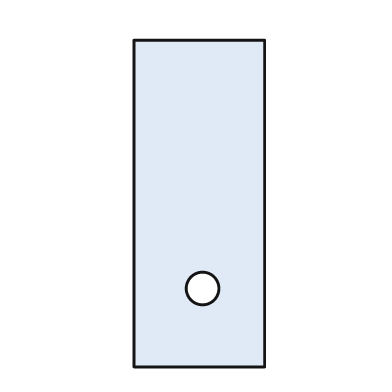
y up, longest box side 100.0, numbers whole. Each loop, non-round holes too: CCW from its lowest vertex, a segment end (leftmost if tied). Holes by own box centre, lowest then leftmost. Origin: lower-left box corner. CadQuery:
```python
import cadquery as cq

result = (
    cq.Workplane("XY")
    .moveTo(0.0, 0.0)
    .lineTo(40.0, 0.0)
    .lineTo(40.0, 100.0)
    .lineTo(0.0, 100.0)
    .close()
    .moveTo(21.0, 24.0)
    .circle(5.0)
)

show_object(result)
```